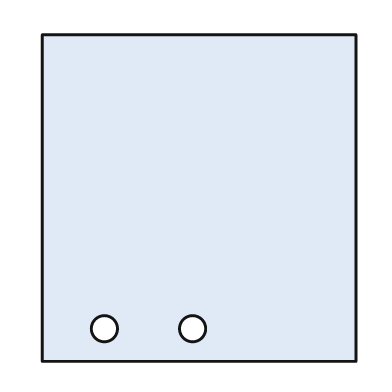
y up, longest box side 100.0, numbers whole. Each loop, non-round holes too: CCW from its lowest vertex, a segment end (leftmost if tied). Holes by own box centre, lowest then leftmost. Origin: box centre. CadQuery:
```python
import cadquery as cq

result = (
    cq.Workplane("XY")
    .moveTo(-48.0, -50.0)
    .lineTo(48.0, -50.0)
    .lineTo(48.0, 50.0)
    .lineTo(-48.0, 50.0)
    .close()
    .moveTo(-29.0, -40.0)
    .circle(4.0)
    .moveTo(-2.0, -40.0)
    .circle(4.0)
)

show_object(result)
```